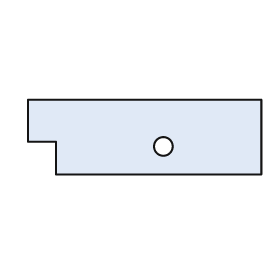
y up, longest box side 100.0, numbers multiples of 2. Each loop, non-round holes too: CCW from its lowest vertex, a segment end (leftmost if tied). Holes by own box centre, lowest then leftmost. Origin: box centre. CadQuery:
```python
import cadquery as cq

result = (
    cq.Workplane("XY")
    .moveTo(-38.0, -16.0)
    .lineTo(50.0, -16.0)
    .lineTo(50.0, 16.0)
    .lineTo(-50.0, 16.0)
    .lineTo(-50.0, -2.0)
    .lineTo(-38.0, -2.0)
    .close()
    .moveTo(8.0, -4.0)
    .circle(4.0)
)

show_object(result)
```